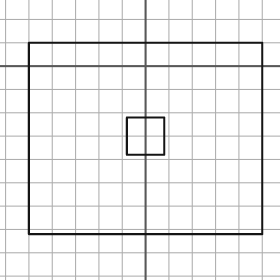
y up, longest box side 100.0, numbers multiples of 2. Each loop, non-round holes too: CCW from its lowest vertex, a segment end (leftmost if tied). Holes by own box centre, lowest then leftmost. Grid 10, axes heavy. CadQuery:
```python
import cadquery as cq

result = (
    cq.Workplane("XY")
    .moveTo(-50.0, -72.0)
    .lineTo(50.0, -72.0)
    .lineTo(50.0, 10.0)
    .lineTo(-50.0, 10.0)
    .close()
    .moveTo(-8.0, -38.0)
    .lineTo(8.0, -38.0)
    .lineTo(8.0, -22.0)
    .lineTo(-8.0, -22.0)
    .close()
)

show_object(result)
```